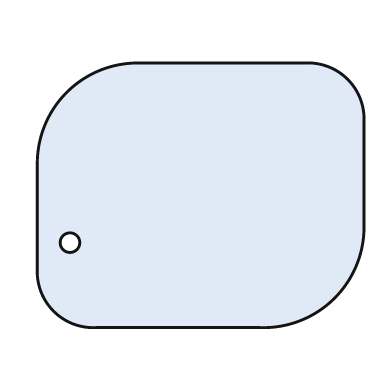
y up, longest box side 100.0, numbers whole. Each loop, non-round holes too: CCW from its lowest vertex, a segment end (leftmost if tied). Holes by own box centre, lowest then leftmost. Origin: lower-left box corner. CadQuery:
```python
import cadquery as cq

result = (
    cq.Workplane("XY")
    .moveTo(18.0, 0.0)
    .lineTo(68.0, 0.0)
    .threePointArc((91.0, 9.0), (100.0, 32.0))
    .lineTo(100.0, 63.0)
    .threePointArc((95.0, 76.0), (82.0, 81.0))
    .lineTo(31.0, 81.0)
    .threePointArc((9.0, 72.0), (0.0, 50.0))
    .lineTo(0.0, 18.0)
    .threePointArc((5.0, 5.0), (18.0, 0.0))
    .close()
    .moveTo(10.0, 26.0)
    .circle(3.0)
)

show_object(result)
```